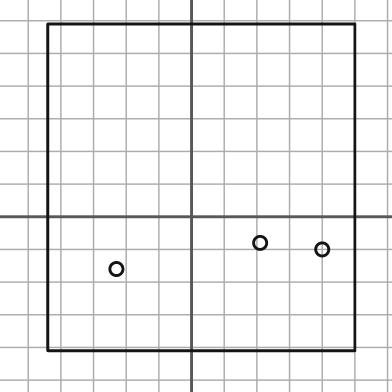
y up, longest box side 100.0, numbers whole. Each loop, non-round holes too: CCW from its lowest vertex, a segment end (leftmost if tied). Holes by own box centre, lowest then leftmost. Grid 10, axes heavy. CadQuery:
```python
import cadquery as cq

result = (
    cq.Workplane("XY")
    .moveTo(-44.0, -41.0)
    .lineTo(50.0, -41.0)
    .lineTo(50.0, 59.0)
    .lineTo(-44.0, 59.0)
    .close()
    .moveTo(-23.0, -16.0)
    .circle(2.0)
    .moveTo(40.0, -10.0)
    .circle(2.0)
    .moveTo(21.0, -8.0)
    .circle(2.0)
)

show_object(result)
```